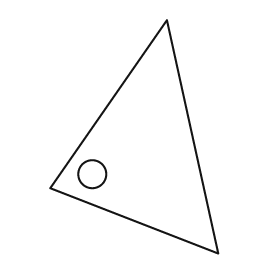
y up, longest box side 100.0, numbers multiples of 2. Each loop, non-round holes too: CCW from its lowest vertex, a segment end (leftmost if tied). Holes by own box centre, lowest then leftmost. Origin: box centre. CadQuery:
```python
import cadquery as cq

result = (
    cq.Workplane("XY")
    .moveTo(36.0, -50.0)
    .lineTo(14.0, 50.0)
    .lineTo(-36.0, -22.0)
    .close()
    .moveTo(-18.0, -16.0)
    .circle(6.0)
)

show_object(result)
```